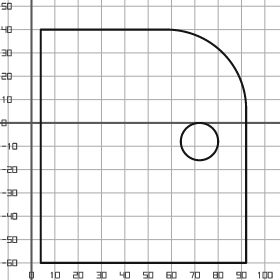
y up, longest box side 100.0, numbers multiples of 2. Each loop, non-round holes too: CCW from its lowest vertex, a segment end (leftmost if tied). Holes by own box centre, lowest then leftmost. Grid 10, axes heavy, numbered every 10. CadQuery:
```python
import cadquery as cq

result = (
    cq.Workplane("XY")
    .moveTo(4.0, -60.0)
    .lineTo(92.0, -60.0)
    .lineTo(92.0, 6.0)
    .threePointArc((82.0, 30.0), (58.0, 40.0))
    .lineTo(4.0, 40.0)
    .close()
    .moveTo(72.0, -8.0)
    .circle(8.0)
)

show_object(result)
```